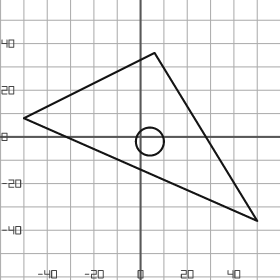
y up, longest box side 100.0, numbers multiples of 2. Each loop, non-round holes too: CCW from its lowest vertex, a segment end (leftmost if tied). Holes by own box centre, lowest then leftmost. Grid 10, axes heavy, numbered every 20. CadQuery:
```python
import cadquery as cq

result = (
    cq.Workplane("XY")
    .moveTo(50.0, -36.0)
    .lineTo(6.0, 36.0)
    .lineTo(-50.0, 8.0)
    .close()
    .moveTo(4.0, -2.0)
    .circle(6.0)
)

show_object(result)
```